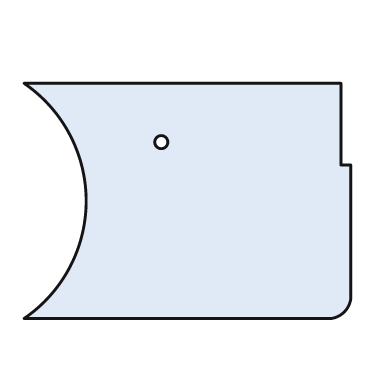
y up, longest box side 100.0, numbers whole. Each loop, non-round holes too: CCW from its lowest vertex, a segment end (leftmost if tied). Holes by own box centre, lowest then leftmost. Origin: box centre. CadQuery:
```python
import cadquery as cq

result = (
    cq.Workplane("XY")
    .moveTo(-50.0, -36.0)
    .lineTo(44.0, -36.0)
    .threePointArc((48.0, -34.0), (50.0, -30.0))
    .lineTo(50.0, 11.0)
    .lineTo(47.0, 11.0)
    .lineTo(47.0, 36.0)
    .lineTo(-50.0, 36.0)
    .threePointArc((-31.0, 0.0), (-50.0, -36.0))
    .close()
    .moveTo(-8.0, 18.0)
    .circle(2.0)
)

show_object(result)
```